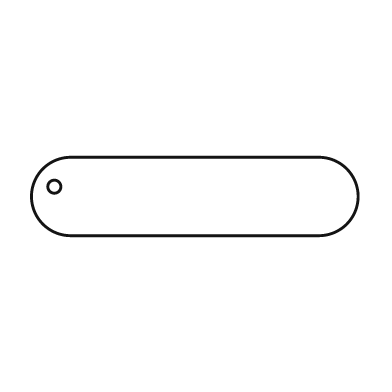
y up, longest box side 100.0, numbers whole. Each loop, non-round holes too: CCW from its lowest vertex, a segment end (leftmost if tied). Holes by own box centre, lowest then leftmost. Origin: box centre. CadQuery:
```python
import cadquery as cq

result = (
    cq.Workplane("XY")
    .moveTo(-38.0, -12.0)
    .lineTo(38.0, -12.0)
    .threePointArc((50.0, 0.0), (38.0, 12.0))
    .lineTo(-38.0, 12.0)
    .threePointArc((-50.0, 0.0), (-38.0, -12.0))
    .close()
    .moveTo(-43.0, 3.0)
    .circle(2.0)
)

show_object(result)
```